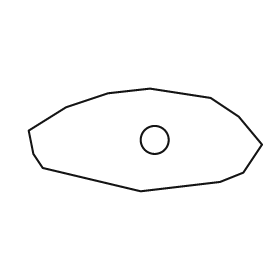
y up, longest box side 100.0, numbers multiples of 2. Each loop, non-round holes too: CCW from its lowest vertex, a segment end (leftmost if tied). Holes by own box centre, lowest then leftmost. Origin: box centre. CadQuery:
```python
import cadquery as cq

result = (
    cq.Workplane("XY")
    .moveTo(-2.0, -22.0)
    .lineTo(32.0, -18.0)
    .lineTo(42.0, -14.0)
    .lineTo(50.0, -2.0)
    .lineTo(40.0, 10.0)
    .lineTo(28.0, 18.0)
    .lineTo(2.0, 22.0)
    .lineTo(-16.0, 20.0)
    .lineTo(-34.0, 14.0)
    .lineTo(-50.0, 4.0)
    .lineTo(-48.0, -6.0)
    .lineTo(-44.0, -12.0)
    .close()
    .moveTo(4.0, 0.0)
    .circle(6.0)
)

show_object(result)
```